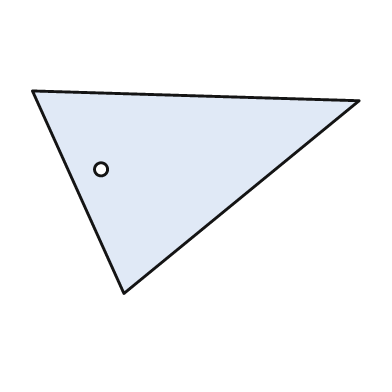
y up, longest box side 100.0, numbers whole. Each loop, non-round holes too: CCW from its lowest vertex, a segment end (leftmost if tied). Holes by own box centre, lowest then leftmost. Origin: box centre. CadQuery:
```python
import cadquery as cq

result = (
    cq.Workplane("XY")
    .moveTo(-22.0, -31.0)
    .lineTo(50.0, 28.0)
    .lineTo(-50.0, 31.0)
    .close()
    .moveTo(-29.0, 7.0)
    .circle(2.0)
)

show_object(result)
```